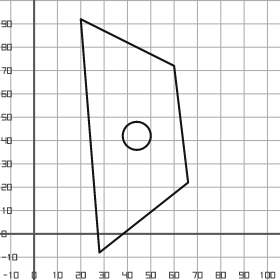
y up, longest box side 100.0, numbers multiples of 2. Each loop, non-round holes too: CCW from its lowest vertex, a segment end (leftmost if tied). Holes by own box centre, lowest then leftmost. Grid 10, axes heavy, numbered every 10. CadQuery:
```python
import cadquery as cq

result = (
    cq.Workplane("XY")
    .moveTo(28.0, -8.0)
    .lineTo(66.0, 22.0)
    .lineTo(60.0, 72.0)
    .lineTo(20.0, 92.0)
    .close()
    .moveTo(44.0, 42.0)
    .circle(6.0)
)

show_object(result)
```